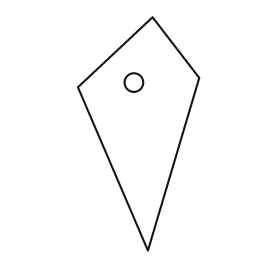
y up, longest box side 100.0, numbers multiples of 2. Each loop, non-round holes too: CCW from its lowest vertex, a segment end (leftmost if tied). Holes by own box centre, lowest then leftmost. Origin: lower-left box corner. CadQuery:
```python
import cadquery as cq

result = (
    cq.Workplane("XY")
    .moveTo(30.0, 0.0)
    .lineTo(52.0, 74.0)
    .lineTo(32.0, 100.0)
    .lineTo(0.0, 70.0)
    .close()
    .moveTo(24.0, 72.0)
    .circle(4.0)
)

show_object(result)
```